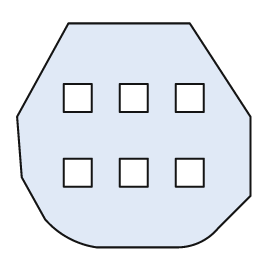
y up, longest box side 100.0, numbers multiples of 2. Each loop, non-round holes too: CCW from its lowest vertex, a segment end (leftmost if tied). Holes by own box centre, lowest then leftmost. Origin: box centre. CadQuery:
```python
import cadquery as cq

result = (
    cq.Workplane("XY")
    .moveTo(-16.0, -48.0)
    .lineTo(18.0, -48.0)
    .threePointArc((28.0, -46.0), (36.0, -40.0))
    .lineTo(50.0, -26.0)
    .lineTo(50.0, 8.0)
    .lineTo(24.0, 48.0)
    .lineTo(-28.0, 48.0)
    .lineTo(-50.0, 8.0)
    .lineTo(-48.0, -18.0)
    .lineTo(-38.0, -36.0)
    .threePointArc((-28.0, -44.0), (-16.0, -48.0))
    .close()
    .moveTo(-30.0, -22.0)
    .lineTo(-18.0, -22.0)
    .lineTo(-18.0, -10.0)
    .lineTo(-30.0, -10.0)
    .close()
    .moveTo(-6.0, -22.0)
    .lineTo(6.0, -22.0)
    .lineTo(6.0, -10.0)
    .lineTo(-6.0, -10.0)
    .close()
    .moveTo(18.0, -22.0)
    .lineTo(30.0, -22.0)
    .lineTo(30.0, -10.0)
    .lineTo(18.0, -10.0)
    .close()
    .moveTo(-30.0, 10.0)
    .lineTo(-18.0, 10.0)
    .lineTo(-18.0, 22.0)
    .lineTo(-30.0, 22.0)
    .close()
    .moveTo(-6.0, 10.0)
    .lineTo(6.0, 10.0)
    .lineTo(6.0, 22.0)
    .lineTo(-6.0, 22.0)
    .close()
    .moveTo(18.0, 10.0)
    .lineTo(30.0, 10.0)
    .lineTo(30.0, 22.0)
    .lineTo(18.0, 22.0)
    .close()
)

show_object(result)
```